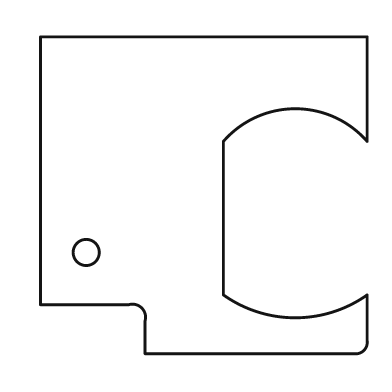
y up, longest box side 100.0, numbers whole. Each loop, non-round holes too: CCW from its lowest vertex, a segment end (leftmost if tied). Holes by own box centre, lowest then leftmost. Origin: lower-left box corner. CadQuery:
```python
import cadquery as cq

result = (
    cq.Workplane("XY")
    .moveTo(32.0, 0.0)
    .lineTo(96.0, 0.0)
    .threePointArc((99.0, 1.0), (100.0, 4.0))
    .lineTo(100.0, 18.0)
    .threePointArc((78.0, 11.0), (56.0, 18.0))
    .lineTo(56.0, 65.0)
    .threePointArc((78.0, 75.0), (100.0, 65.0))
    .lineTo(100.0, 97.0)
    .lineTo(0.0, 97.0)
    .lineTo(0.0, 15.0)
    .lineTo(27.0, 15.0)
    .threePointArc((31.0, 14.0), (32.0, 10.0))
    .close()
    .moveTo(14.0, 31.0)
    .circle(4.0)
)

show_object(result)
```